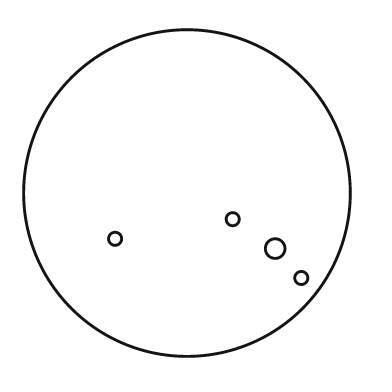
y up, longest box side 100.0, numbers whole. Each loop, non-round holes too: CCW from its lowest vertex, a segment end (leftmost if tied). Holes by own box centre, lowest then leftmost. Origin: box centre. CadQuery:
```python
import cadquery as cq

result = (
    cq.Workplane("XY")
    .moveTo(0.0, 0.0)
    .circle(50.0)
    .moveTo(35.0, -26.0)
    .circle(2.0)
    .moveTo(27.0, -17.0)
    .circle(3.0)
    .moveTo(-22.0, -14.0)
    .circle(2.0)
    .moveTo(14.0, -8.0)
    .circle(2.0)
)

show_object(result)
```